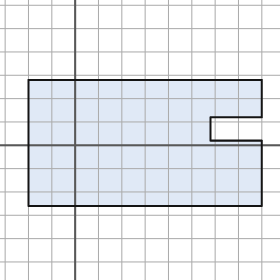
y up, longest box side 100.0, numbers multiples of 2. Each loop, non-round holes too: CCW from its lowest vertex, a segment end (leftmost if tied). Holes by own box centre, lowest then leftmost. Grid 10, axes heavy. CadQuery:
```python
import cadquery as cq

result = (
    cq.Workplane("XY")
    .moveTo(-20.0, -26.0)
    .lineTo(80.0, -26.0)
    .lineTo(80.0, 2.0)
    .lineTo(58.0, 2.0)
    .lineTo(58.0, 12.0)
    .lineTo(80.0, 12.0)
    .lineTo(80.0, 28.0)
    .lineTo(-20.0, 28.0)
    .close()
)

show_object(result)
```